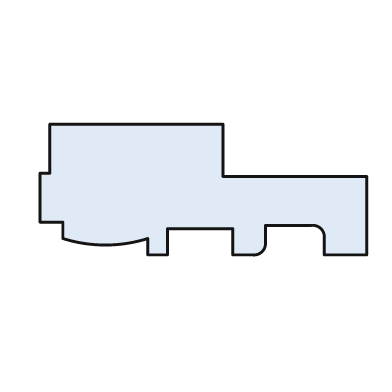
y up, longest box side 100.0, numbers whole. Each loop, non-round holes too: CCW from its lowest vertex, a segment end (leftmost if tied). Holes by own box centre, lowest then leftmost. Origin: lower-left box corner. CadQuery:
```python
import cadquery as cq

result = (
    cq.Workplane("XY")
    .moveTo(33.0, 0.0)
    .lineTo(39.0, 0.0)
    .lineTo(39.0, 8.0)
    .lineTo(59.0, 8.0)
    .lineTo(59.0, 0.0)
    .lineTo(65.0, 0.0)
    .threePointArc((68.0, 1.0), (69.0, 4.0))
    .lineTo(69.0, 9.0)
    .lineTo(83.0, 9.0)
    .threePointArc((86.0, 8.0), (87.0, 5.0))
    .lineTo(87.0, 0.0)
    .lineTo(100.0, 0.0)
    .lineTo(100.0, 24.0)
    .lineTo(56.0, 24.0)
    .lineTo(56.0, 40.0)
    .lineTo(3.0, 40.0)
    .lineTo(3.0, 25.0)
    .lineTo(0.0, 25.0)
    .lineTo(0.0, 10.0)
    .lineTo(7.0, 10.0)
    .lineTo(7.0, 5.0)
    .threePointArc((20.0, 3.0), (33.0, 5.0))
    .close()
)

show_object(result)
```